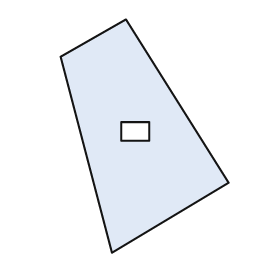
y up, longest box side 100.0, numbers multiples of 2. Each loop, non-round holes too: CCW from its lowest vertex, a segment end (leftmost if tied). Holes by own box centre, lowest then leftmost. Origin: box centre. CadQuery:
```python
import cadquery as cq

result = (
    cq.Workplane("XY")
    .moveTo(-14.0, -50.0)
    .lineTo(36.0, -20.0)
    .lineTo(-8.0, 50.0)
    .lineTo(-36.0, 34.0)
    .close()
    .moveTo(-10.0, -2.0)
    .lineTo(2.0, -2.0)
    .lineTo(2.0, 6.0)
    .lineTo(-10.0, 6.0)
    .close()
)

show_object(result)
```